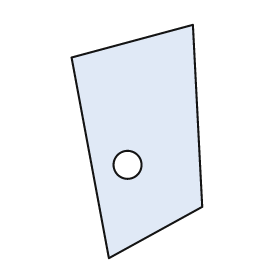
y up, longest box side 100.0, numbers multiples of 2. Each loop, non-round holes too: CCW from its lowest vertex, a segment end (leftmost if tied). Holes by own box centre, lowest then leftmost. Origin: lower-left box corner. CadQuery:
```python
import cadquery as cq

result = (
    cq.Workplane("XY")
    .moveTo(16.0, 0.0)
    .lineTo(56.0, 22.0)
    .lineTo(52.0, 100.0)
    .lineTo(0.0, 86.0)
    .close()
    .moveTo(24.0, 40.0)
    .circle(6.0)
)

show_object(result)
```